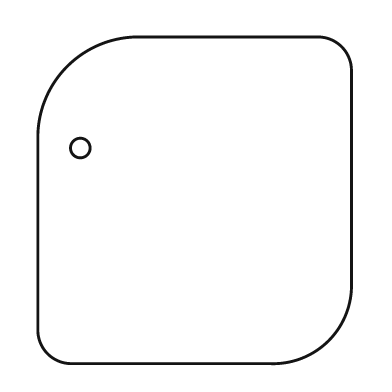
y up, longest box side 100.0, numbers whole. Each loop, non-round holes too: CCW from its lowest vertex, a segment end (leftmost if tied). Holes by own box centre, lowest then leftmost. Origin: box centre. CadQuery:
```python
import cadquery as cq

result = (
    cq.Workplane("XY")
    .moveTo(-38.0, -50.0)
    .lineTo(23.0, -50.0)
    .threePointArc((41.0, -43.0), (48.0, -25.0))
    .lineTo(48.0, 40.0)
    .threePointArc((45.0, 47.0), (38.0, 50.0))
    .lineTo(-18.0, 50.0)
    .threePointArc((-39.0, 41.0), (-48.0, 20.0))
    .lineTo(-48.0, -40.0)
    .threePointArc((-45.0, -47.0), (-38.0, -50.0))
    .close()
    .moveTo(-35.0, 16.0)
    .circle(3.0)
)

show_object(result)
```